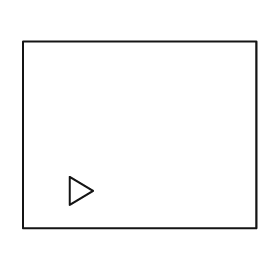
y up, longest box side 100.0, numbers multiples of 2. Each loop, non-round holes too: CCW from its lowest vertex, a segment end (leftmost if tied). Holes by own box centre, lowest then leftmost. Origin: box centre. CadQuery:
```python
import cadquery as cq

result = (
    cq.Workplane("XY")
    .moveTo(-50.0, -40.0)
    .lineTo(50.0, -40.0)
    .lineTo(50.0, 40.0)
    .lineTo(-50.0, 40.0)
    .close()
    .moveTo(-30.0, -30.0)
    .lineTo(-20.0, -24.0)
    .lineTo(-30.0, -18.0)
    .close()
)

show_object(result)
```